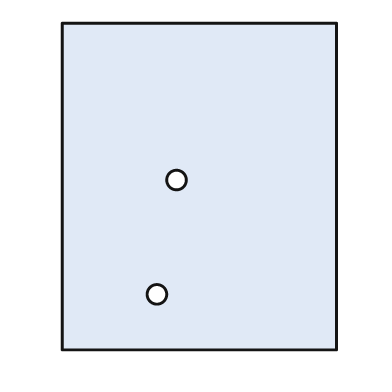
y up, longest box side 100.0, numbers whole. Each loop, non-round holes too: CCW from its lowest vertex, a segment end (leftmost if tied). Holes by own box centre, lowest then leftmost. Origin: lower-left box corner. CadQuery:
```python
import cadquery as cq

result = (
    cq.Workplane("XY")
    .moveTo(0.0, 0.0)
    .lineTo(84.0, 0.0)
    .lineTo(84.0, 100.0)
    .lineTo(0.0, 100.0)
    .close()
    .moveTo(29.0, 17.0)
    .circle(3.0)
    .moveTo(35.0, 52.0)
    .circle(3.0)
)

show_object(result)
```